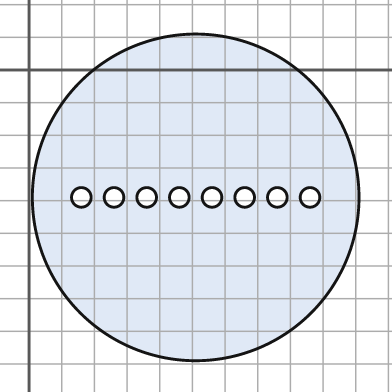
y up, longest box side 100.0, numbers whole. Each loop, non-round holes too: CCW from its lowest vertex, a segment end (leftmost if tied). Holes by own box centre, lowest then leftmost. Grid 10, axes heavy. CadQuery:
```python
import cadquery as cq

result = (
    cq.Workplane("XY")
    .moveTo(51.0, -39.0)
    .circle(50.0)
    .moveTo(16.0, -39.0)
    .circle(3.0)
    .moveTo(26.0, -39.0)
    .circle(3.0)
    .moveTo(36.0, -39.0)
    .circle(3.0)
    .moveTo(46.0, -39.0)
    .circle(3.0)
    .moveTo(56.0, -39.0)
    .circle(3.0)
    .moveTo(66.0, -39.0)
    .circle(3.0)
    .moveTo(76.0, -39.0)
    .circle(3.0)
    .moveTo(86.0, -39.0)
    .circle(3.0)
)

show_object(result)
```